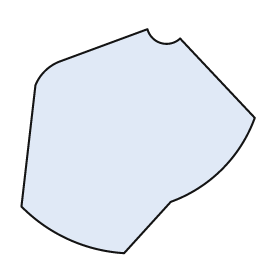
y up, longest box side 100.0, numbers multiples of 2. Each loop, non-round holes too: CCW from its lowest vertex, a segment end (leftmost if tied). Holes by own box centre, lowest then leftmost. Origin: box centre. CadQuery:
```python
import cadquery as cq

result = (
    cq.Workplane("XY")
    .moveTo(-6.0, -48.0)
    .lineTo(14.0, -26.0)
    .threePointArc((36.0, -12.0), (50.0, 10.0))
    .lineTo(18.0, 44.0)
    .threePointArc((10.0, 42.0), (4.0, 48.0))
    .lineTo(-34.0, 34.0)
    .threePointArc((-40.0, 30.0), (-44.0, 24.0))
    .lineTo(-50.0, -28.0)
    .threePointArc((-30.0, -42.0), (-6.0, -48.0))
    .close()
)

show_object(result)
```